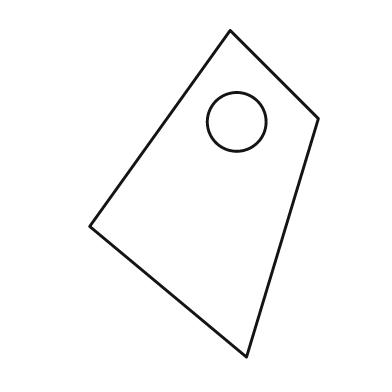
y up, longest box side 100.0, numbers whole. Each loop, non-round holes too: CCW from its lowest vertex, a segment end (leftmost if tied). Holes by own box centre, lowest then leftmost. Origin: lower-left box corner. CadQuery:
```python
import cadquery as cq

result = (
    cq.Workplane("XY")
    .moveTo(48.0, 0.0)
    .lineTo(70.0, 73.0)
    .lineTo(43.0, 100.0)
    .lineTo(0.0, 40.0)
    .close()
    .moveTo(45.0, 72.0)
    .circle(9.0)
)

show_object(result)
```